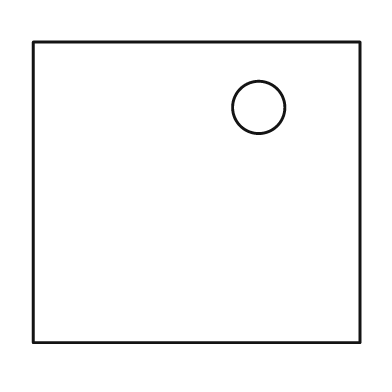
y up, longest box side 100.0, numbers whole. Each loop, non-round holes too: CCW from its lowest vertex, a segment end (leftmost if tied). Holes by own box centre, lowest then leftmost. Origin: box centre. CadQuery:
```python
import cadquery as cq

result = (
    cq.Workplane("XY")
    .moveTo(-50.0, -46.0)
    .lineTo(50.0, -46.0)
    .lineTo(50.0, 46.0)
    .lineTo(-50.0, 46.0)
    .close()
    .moveTo(19.0, 26.0)
    .circle(8.0)
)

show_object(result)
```